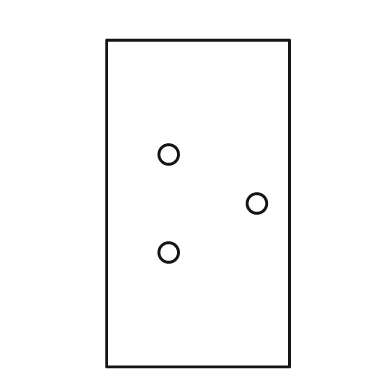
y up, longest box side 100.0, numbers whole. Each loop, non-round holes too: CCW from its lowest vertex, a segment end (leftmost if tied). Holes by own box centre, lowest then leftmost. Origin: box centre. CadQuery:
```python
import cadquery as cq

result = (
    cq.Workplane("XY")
    .moveTo(-28.0, -50.0)
    .lineTo(28.0, -50.0)
    .lineTo(28.0, 50.0)
    .lineTo(-28.0, 50.0)
    .close()
    .moveTo(-9.0, -15.0)
    .circle(3.0)
    .moveTo(18.0, 0.0)
    .circle(3.0)
    .moveTo(-9.0, 15.0)
    .circle(3.0)
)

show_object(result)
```